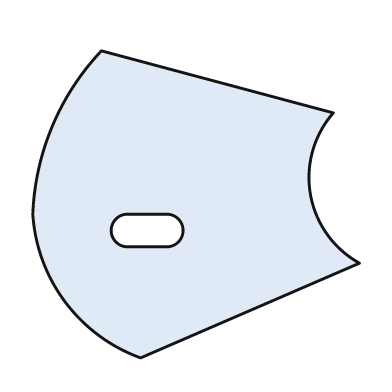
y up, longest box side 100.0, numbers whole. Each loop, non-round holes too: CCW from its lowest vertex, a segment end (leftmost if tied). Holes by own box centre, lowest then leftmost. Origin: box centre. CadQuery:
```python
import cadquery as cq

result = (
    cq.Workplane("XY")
    .moveTo(-17.0, -47.0)
    .lineTo(50.0, -18.0)
    .threePointArc((35.0, 3.0), (42.0, 28.0))
    .lineTo(-29.0, 47.0)
    .threePointArc((-44.0, 24.0), (-50.0, -3.0))
    .threePointArc((-40.0, -30.0), (-17.0, -47.0))
    .close()
    .moveTo(-21.0, -13.0)
    .lineTo(-9.0, -13.0)
    .threePointArc((-4.0, -8.0), (-9.0, -3.0))
    .lineTo(-21.0, -3.0)
    .threePointArc((-26.0, -8.0), (-21.0, -13.0))
    .close()
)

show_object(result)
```